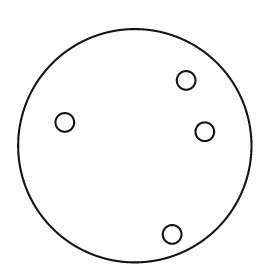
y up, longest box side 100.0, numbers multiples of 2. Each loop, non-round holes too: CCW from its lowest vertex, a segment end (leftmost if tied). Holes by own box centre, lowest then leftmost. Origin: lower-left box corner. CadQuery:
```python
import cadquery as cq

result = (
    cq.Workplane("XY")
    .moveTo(50.0, 50.0)
    .circle(50.0)
    .moveTo(66.0, 12.0)
    .circle(4.0)
    .moveTo(80.0, 56.0)
    .circle(4.0)
    .moveTo(20.0, 60.0)
    .circle(4.0)
    .moveTo(72.0, 78.0)
    .circle(4.0)
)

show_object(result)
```